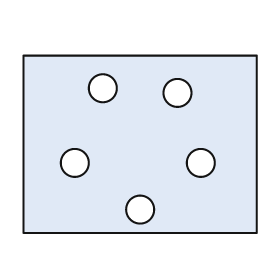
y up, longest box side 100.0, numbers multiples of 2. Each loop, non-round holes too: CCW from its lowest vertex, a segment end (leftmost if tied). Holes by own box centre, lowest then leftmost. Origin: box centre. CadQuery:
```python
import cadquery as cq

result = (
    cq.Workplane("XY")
    .moveTo(-50.0, -38.0)
    .lineTo(50.0, -38.0)
    .lineTo(50.0, 38.0)
    .lineTo(-50.0, 38.0)
    .close()
    .moveTo(0.0, -28.0)
    .circle(6.0)
    .moveTo(-28.0, -8.0)
    .circle(6.0)
    .moveTo(26.0, -8.0)
    .circle(6.0)
    .moveTo(16.0, 22.0)
    .circle(6.0)
    .moveTo(-16.0, 24.0)
    .circle(6.0)
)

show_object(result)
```